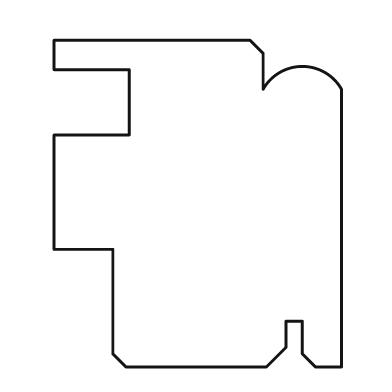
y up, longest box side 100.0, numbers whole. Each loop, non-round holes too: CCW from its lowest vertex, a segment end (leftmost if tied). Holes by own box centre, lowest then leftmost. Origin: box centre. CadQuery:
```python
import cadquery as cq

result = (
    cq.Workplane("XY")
    .moveTo(-22.0, -50.0)
    .lineTo(21.0, -50.0)
    .lineTo(27.0, -44.0)
    .lineTo(27.0, -36.0)
    .lineTo(32.0, -36.0)
    .lineTo(32.0, -46.0)
    .lineTo(36.0, -50.0)
    .lineTo(44.0, -50.0)
    .lineTo(44.0, 35.0)
    .threePointArc((32.0, 42.0), (20.0, 35.0))
    .lineTo(20.0, 46.0)
    .lineTo(16.0, 50.0)
    .lineTo(-44.0, 50.0)
    .lineTo(-44.0, 41.0)
    .lineTo(-21.0, 41.0)
    .lineTo(-21.0, 21.0)
    .lineTo(-44.0, 21.0)
    .lineTo(-44.0, -14.0)
    .lineTo(-26.0, -14.0)
    .lineTo(-26.0, -46.0)
    .close()
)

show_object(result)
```